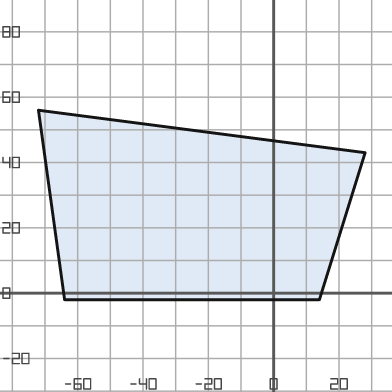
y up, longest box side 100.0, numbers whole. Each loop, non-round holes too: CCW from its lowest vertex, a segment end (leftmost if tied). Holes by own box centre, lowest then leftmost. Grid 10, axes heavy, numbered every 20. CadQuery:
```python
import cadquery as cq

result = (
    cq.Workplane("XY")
    .moveTo(-64.0, -2.0)
    .lineTo(14.0, -2.0)
    .lineTo(28.0, 43.0)
    .lineTo(-72.0, 56.0)
    .close()
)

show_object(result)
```